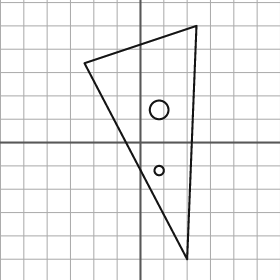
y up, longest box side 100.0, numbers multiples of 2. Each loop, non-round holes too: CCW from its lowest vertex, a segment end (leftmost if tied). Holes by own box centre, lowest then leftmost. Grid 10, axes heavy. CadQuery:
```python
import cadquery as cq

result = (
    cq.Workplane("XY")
    .moveTo(20.0, -50.0)
    .lineTo(24.0, 50.0)
    .lineTo(-24.0, 34.0)
    .close()
    .moveTo(8.0, -12.0)
    .circle(2.0)
    .moveTo(8.0, 14.0)
    .circle(4.0)
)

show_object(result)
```